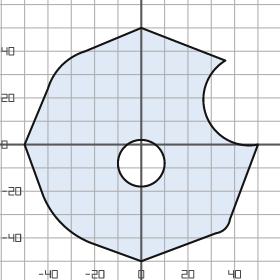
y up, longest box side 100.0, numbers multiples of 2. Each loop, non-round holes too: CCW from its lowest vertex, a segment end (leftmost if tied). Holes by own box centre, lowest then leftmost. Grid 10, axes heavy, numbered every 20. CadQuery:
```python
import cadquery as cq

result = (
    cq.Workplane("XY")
    .moveTo(0.0, -50.0)
    .lineTo(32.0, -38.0)
    .threePointArc((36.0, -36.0), (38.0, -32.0))
    .lineTo(50.0, 0.0)
    .threePointArc((28.0, 12.0), (36.0, 36.0))
    .lineTo(0.0, 50.0)
    .lineTo(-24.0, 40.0)
    .threePointArc((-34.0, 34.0), (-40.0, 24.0))
    .lineTo(-50.0, 0.0)
    .lineTo(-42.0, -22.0)
    .threePointArc((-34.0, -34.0), (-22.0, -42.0))
    .close()
    .moveTo(0.0, -8.0)
    .circle(10.0)
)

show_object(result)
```